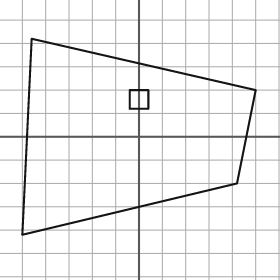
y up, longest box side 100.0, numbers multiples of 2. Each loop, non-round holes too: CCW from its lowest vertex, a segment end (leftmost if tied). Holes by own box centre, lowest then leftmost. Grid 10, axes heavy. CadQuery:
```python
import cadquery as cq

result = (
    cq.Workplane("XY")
    .moveTo(-50.0, -42.0)
    .lineTo(42.0, -20.0)
    .lineTo(50.0, 20.0)
    .lineTo(-46.0, 42.0)
    .close()
    .moveTo(-4.0, 12.0)
    .lineTo(4.0, 12.0)
    .lineTo(4.0, 20.0)
    .lineTo(-4.0, 20.0)
    .close()
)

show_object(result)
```